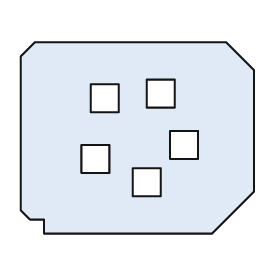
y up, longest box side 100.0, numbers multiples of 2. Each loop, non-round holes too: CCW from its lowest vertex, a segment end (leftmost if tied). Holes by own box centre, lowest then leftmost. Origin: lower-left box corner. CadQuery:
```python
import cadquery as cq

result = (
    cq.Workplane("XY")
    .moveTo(10.0, 0.0)
    .lineTo(82.0, 0.0)
    .lineTo(100.0, 18.0)
    .lineTo(100.0, 70.0)
    .lineTo(88.0, 82.0)
    .lineTo(6.0, 82.0)
    .lineTo(0.0, 76.0)
    .lineTo(0.0, 10.0)
    .lineTo(4.0, 6.0)
    .lineTo(10.0, 6.0)
    .close()
    .moveTo(48.0, 16.0)
    .lineTo(60.0, 16.0)
    .lineTo(60.0, 28.0)
    .lineTo(48.0, 28.0)
    .close()
    .moveTo(26.0, 26.0)
    .lineTo(38.0, 26.0)
    .lineTo(38.0, 38.0)
    .lineTo(26.0, 38.0)
    .close()
    .moveTo(64.0, 32.0)
    .lineTo(76.0, 32.0)
    .lineTo(76.0, 44.0)
    .lineTo(64.0, 44.0)
    .close()
    .moveTo(30.0, 52.0)
    .lineTo(42.0, 52.0)
    .lineTo(42.0, 64.0)
    .lineTo(30.0, 64.0)
    .close()
    .moveTo(54.0, 54.0)
    .lineTo(66.0, 54.0)
    .lineTo(66.0, 66.0)
    .lineTo(54.0, 66.0)
    .close()
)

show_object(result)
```